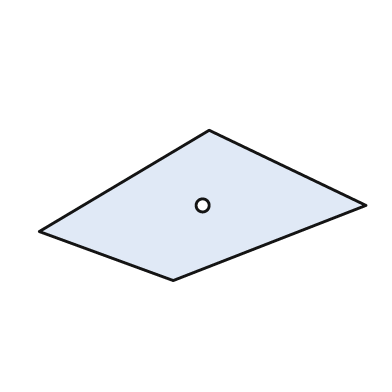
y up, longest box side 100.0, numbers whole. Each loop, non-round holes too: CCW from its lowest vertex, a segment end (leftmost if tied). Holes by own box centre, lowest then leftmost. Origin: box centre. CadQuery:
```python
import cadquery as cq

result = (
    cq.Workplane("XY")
    .moveTo(-9.0, -23.0)
    .lineTo(50.0, 0.0)
    .lineTo(2.0, 23.0)
    .lineTo(-50.0, -8.0)
    .close()
    .moveTo(0.0, 0.0)
    .circle(2.0)
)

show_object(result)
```